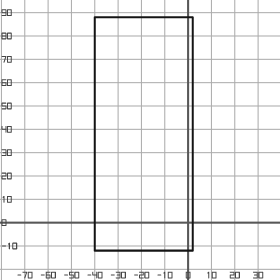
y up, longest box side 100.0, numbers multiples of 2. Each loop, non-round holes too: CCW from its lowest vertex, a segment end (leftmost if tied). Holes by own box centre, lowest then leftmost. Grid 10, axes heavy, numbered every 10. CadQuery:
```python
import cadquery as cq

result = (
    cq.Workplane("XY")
    .moveTo(-40.0, -12.0)
    .lineTo(2.0, -12.0)
    .lineTo(2.0, 88.0)
    .lineTo(-40.0, 88.0)
    .close()
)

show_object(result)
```